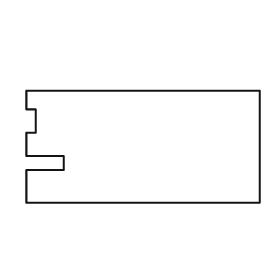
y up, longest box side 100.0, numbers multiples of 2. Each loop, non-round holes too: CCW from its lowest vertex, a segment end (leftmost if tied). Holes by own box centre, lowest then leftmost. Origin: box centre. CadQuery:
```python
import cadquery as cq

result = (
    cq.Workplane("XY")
    .moveTo(-50.0, -24.0)
    .lineTo(50.0, -24.0)
    .lineTo(50.0, 24.0)
    .lineTo(-50.0, 24.0)
    .lineTo(-50.0, 16.0)
    .lineTo(-46.0, 16.0)
    .lineTo(-46.0, 6.0)
    .lineTo(-50.0, 6.0)
    .lineTo(-50.0, -4.0)
    .lineTo(-34.0, -4.0)
    .lineTo(-34.0, -10.0)
    .lineTo(-50.0, -10.0)
    .close()
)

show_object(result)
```